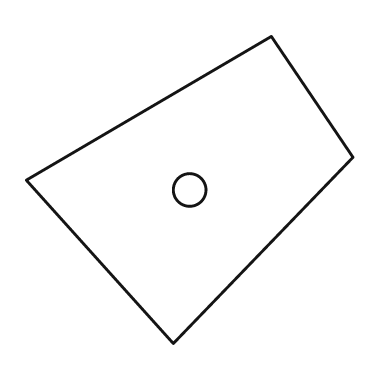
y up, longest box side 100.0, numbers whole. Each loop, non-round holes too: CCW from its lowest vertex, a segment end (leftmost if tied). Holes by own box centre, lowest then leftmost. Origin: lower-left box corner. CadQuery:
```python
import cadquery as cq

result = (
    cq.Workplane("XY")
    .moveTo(45.0, 0.0)
    .lineTo(100.0, 57.0)
    .lineTo(75.0, 94.0)
    .lineTo(0.0, 50.0)
    .close()
    .moveTo(50.0, 47.0)
    .circle(5.0)
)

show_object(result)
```